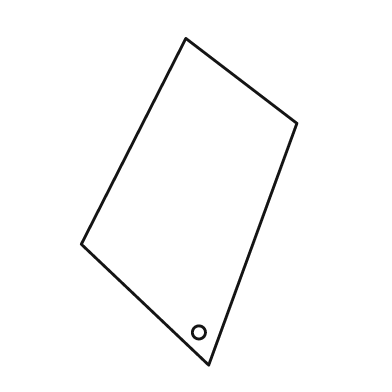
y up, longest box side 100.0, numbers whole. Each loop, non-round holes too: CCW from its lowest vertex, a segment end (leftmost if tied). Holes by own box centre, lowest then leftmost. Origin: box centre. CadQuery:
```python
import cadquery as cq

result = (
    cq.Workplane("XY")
    .moveTo(6.0, -50.0)
    .lineTo(33.0, 24.0)
    .lineTo(-1.0, 50.0)
    .lineTo(-33.0, -13.0)
    .close()
    .moveTo(3.0, -40.0)
    .circle(2.0)
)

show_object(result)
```